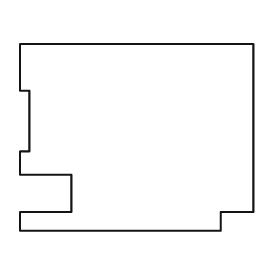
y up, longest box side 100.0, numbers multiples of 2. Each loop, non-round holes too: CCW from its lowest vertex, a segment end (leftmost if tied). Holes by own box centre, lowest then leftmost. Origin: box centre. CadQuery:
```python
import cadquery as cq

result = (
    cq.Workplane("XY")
    .moveTo(-50.0, -40.0)
    .lineTo(36.0, -40.0)
    .lineTo(36.0, -32.0)
    .lineTo(50.0, -32.0)
    .lineTo(50.0, 40.0)
    .lineTo(-50.0, 40.0)
    .lineTo(-50.0, 20.0)
    .lineTo(-46.0, 20.0)
    .lineTo(-46.0, -6.0)
    .lineTo(-50.0, -6.0)
    .lineTo(-50.0, -16.0)
    .lineTo(-28.0, -16.0)
    .lineTo(-28.0, -32.0)
    .lineTo(-50.0, -32.0)
    .close()
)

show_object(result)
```